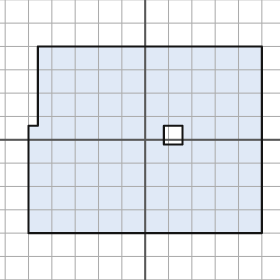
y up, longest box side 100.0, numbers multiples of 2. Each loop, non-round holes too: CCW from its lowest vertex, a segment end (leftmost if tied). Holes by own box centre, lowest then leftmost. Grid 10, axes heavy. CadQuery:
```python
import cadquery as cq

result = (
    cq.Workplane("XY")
    .moveTo(-50.0, -40.0)
    .lineTo(50.0, -40.0)
    .lineTo(50.0, 40.0)
    .lineTo(-46.0, 40.0)
    .lineTo(-46.0, 6.0)
    .lineTo(-50.0, 6.0)
    .close()
    .moveTo(8.0, -2.0)
    .lineTo(16.0, -2.0)
    .lineTo(16.0, 6.0)
    .lineTo(8.0, 6.0)
    .close()
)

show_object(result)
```